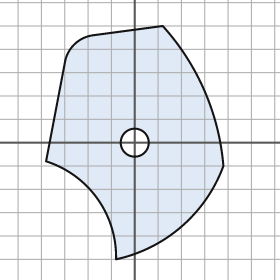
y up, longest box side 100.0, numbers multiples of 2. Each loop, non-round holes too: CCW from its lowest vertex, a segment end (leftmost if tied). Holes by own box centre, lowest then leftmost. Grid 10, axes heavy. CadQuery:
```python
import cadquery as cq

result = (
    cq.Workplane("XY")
    .moveTo(-8.0, -50.0)
    .threePointArc((20.0, -36.0), (38.0, -10.0))
    .threePointArc((30.0, 22.0), (12.0, 50.0))
    .lineTo(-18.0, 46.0)
    .threePointArc((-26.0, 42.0), (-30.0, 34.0))
    .lineTo(-38.0, -8.0)
    .threePointArc((-16.0, -24.0), (-8.0, -50.0))
    .close()
    .moveTo(0.0, 0.0)
    .circle(6.0)
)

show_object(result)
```